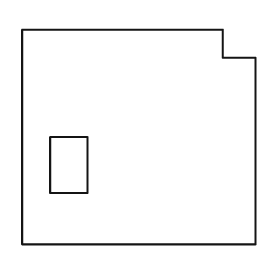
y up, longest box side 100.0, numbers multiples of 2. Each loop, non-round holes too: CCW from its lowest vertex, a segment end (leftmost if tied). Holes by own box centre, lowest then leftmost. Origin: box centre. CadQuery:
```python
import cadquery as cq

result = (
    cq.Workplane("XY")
    .moveTo(-50.0, -46.0)
    .lineTo(50.0, -46.0)
    .lineTo(50.0, 34.0)
    .lineTo(36.0, 34.0)
    .lineTo(36.0, 46.0)
    .lineTo(-50.0, 46.0)
    .close()
    .moveTo(-38.0, -24.0)
    .lineTo(-22.0, -24.0)
    .lineTo(-22.0, 0.0)
    .lineTo(-38.0, 0.0)
    .close()
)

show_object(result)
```